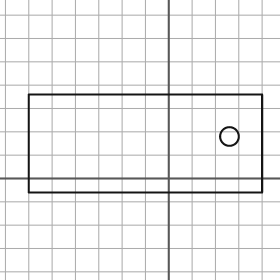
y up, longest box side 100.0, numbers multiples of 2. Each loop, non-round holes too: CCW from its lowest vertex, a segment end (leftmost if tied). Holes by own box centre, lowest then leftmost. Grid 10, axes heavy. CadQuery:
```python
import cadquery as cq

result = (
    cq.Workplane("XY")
    .moveTo(-60.0, -6.0)
    .lineTo(40.0, -6.0)
    .lineTo(40.0, 36.0)
    .lineTo(-60.0, 36.0)
    .close()
    .moveTo(26.0, 18.0)
    .circle(4.0)
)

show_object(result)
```